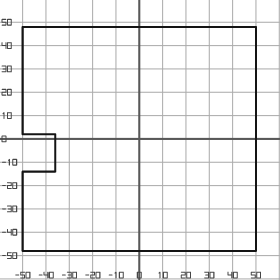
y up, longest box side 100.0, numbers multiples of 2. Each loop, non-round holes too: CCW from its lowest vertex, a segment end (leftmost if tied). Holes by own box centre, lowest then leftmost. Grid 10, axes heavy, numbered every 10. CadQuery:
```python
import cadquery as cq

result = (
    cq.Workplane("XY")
    .moveTo(-50.0, -48.0)
    .lineTo(50.0, -48.0)
    .lineTo(50.0, 48.0)
    .lineTo(-50.0, 48.0)
    .lineTo(-50.0, 2.0)
    .lineTo(-36.0, 2.0)
    .lineTo(-36.0, -14.0)
    .lineTo(-50.0, -14.0)
    .close()
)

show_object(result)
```